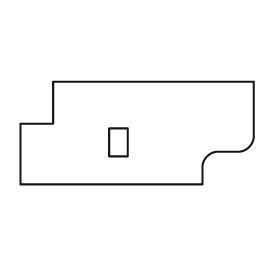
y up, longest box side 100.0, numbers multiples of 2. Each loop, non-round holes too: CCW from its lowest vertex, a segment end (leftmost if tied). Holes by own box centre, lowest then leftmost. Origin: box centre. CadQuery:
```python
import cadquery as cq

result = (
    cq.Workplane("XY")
    .moveTo(-50.0, -22.0)
    .lineTo(28.0, -22.0)
    .lineTo(28.0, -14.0)
    .threePointArc((30.0, -10.0), (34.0, -8.0))
    .lineTo(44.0, -8.0)
    .threePointArc((48.0, -6.0), (50.0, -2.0))
    .lineTo(50.0, 22.0)
    .lineTo(-36.0, 22.0)
    .lineTo(-36.0, 4.0)
    .lineTo(-50.0, 4.0)
    .close()
    .moveTo(-12.0, -10.0)
    .lineTo(-4.0, -10.0)
    .lineTo(-4.0, 2.0)
    .lineTo(-12.0, 2.0)
    .close()
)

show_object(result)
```